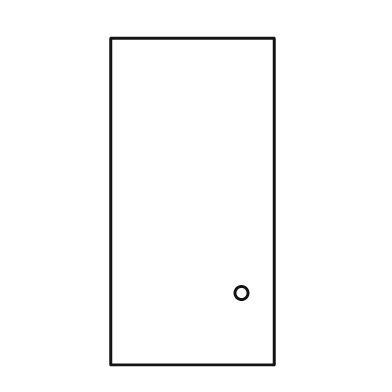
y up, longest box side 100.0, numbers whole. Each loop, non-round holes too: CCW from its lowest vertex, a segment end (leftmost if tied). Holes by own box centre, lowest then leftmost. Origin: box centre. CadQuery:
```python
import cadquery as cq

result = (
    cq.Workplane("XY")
    .moveTo(-25.0, -50.0)
    .lineTo(25.0, -50.0)
    .lineTo(25.0, 50.0)
    .lineTo(-25.0, 50.0)
    .close()
    .moveTo(15.0, -28.0)
    .circle(2.0)
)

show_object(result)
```